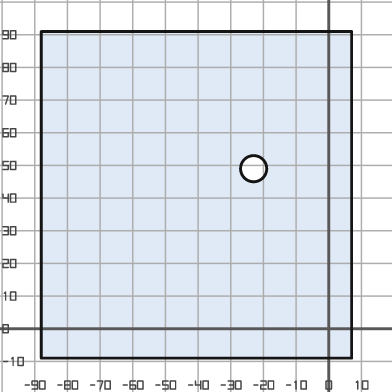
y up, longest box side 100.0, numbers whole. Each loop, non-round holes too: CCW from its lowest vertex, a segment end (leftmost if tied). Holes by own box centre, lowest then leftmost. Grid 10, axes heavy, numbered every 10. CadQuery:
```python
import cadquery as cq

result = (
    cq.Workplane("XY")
    .moveTo(-88.0, -9.0)
    .lineTo(7.0, -9.0)
    .lineTo(7.0, 91.0)
    .lineTo(-88.0, 91.0)
    .close()
    .moveTo(-23.0, 49.0)
    .circle(4.0)
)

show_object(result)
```